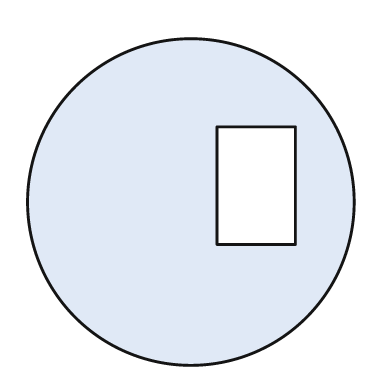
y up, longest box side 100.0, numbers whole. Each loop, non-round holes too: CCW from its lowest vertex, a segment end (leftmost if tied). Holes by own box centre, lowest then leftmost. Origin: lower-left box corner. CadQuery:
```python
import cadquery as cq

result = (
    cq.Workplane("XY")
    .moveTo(50.0, 50.0)
    .circle(50.0)
    .moveTo(58.0, 37.0)
    .lineTo(82.0, 37.0)
    .lineTo(82.0, 73.0)
    .lineTo(58.0, 73.0)
    .close()
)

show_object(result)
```